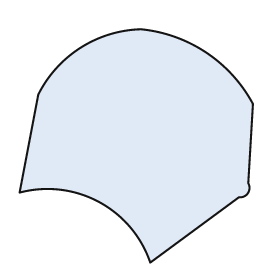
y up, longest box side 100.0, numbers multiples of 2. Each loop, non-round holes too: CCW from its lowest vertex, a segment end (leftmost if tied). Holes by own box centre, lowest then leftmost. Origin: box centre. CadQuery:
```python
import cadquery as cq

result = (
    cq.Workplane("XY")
    .moveTo(6.0, -50.0)
    .lineTo(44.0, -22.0)
    .threePointArc((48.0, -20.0), (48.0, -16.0))
    .lineTo(50.0, 18.0)
    .threePointArc((30.0, 40.0), (2.0, 50.0))
    .threePointArc((-24.0, 42.0), (-42.0, 22.0))
    .lineTo(-50.0, -20.0)
    .threePointArc((-16.0, -24.0), (6.0, -50.0))
    .close()
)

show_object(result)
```